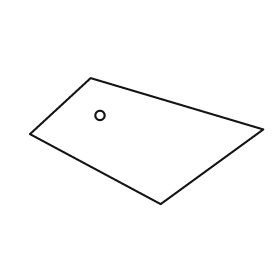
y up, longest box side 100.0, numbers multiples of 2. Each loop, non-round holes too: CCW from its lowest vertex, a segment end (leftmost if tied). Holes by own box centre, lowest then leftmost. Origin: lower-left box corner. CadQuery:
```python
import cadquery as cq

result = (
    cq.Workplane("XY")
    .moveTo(56.0, 0.0)
    .lineTo(100.0, 32.0)
    .lineTo(26.0, 54.0)
    .lineTo(0.0, 30.0)
    .close()
    .moveTo(30.0, 38.0)
    .circle(2.0)
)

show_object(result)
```